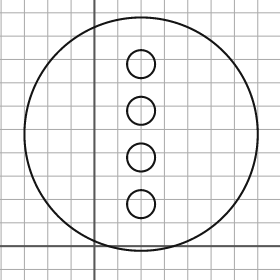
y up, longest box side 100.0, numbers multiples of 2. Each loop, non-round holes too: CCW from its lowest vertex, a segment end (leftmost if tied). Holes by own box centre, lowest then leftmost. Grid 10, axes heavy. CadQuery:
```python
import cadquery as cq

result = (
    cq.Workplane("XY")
    .moveTo(20.0, 48.0)
    .circle(50.0)
    .moveTo(20.0, 18.0)
    .circle(6.0)
    .moveTo(20.0, 38.0)
    .circle(6.0)
    .moveTo(20.0, 58.0)
    .circle(6.0)
    .moveTo(20.0, 78.0)
    .circle(6.0)
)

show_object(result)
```